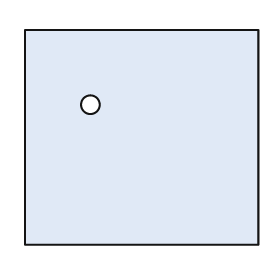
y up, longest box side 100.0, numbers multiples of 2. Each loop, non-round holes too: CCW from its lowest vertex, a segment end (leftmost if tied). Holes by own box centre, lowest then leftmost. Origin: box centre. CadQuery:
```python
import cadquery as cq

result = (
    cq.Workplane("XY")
    .moveTo(-50.0, -46.0)
    .lineTo(50.0, -46.0)
    .lineTo(50.0, 46.0)
    .lineTo(-50.0, 46.0)
    .close()
    .moveTo(-22.0, 14.0)
    .circle(4.0)
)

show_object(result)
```